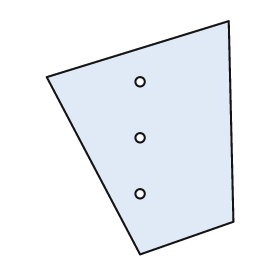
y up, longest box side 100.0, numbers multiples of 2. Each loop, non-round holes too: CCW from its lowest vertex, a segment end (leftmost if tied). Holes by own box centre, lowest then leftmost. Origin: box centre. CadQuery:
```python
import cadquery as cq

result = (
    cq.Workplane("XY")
    .moveTo(0.0, -50.0)
    .lineTo(40.0, -36.0)
    .lineTo(38.0, 50.0)
    .lineTo(-40.0, 26.0)
    .close()
    .moveTo(0.0, -24.0)
    .circle(2.0)
    .moveTo(0.0, 0.0)
    .circle(2.0)
    .moveTo(0.0, 24.0)
    .circle(2.0)
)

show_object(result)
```